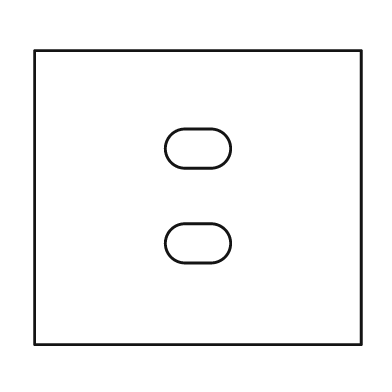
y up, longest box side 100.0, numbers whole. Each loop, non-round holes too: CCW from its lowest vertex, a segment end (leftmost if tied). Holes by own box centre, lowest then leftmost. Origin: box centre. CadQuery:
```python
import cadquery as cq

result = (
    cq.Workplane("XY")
    .moveTo(-50.0, -45.0)
    .lineTo(50.0, -45.0)
    .lineTo(50.0, 45.0)
    .lineTo(-50.0, 45.0)
    .close()
    .moveTo(-4.0, -20.0)
    .lineTo(4.0, -20.0)
    .threePointArc((10.0, -14.0), (4.0, -8.0))
    .lineTo(-4.0, -8.0)
    .threePointArc((-10.0, -14.0), (-4.0, -20.0))
    .close()
    .moveTo(-4.0, 9.0)
    .lineTo(4.0, 9.0)
    .threePointArc((10.0, 15.0), (4.0, 21.0))
    .lineTo(-4.0, 21.0)
    .threePointArc((-10.0, 15.0), (-4.0, 9.0))
    .close()
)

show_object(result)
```